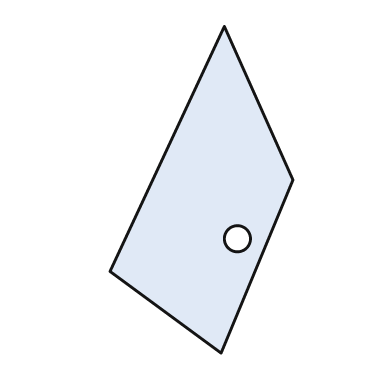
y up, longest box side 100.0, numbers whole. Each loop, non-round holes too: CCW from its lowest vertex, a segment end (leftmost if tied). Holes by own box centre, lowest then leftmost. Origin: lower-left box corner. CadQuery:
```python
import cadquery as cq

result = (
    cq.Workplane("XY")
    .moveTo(34.0, 0.0)
    .lineTo(56.0, 53.0)
    .lineTo(35.0, 100.0)
    .lineTo(0.0, 25.0)
    .close()
    .moveTo(39.0, 35.0)
    .circle(4.0)
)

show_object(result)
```